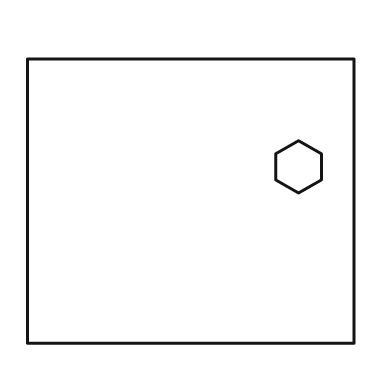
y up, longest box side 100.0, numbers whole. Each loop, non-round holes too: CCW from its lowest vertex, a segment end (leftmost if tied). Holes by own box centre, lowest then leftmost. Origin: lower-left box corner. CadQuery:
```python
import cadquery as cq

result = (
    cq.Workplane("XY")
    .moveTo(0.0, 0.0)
    .lineTo(100.0, 0.0)
    .lineTo(100.0, 87.0)
    .lineTo(0.0, 87.0)
    .close()
    .moveTo(83.0, 46.0)
    .lineTo(90.0, 50.0)
    .lineTo(90.0, 58.0)
    .lineTo(83.0, 62.0)
    .lineTo(76.0, 58.0)
    .lineTo(76.0, 50.0)
    .close()
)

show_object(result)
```